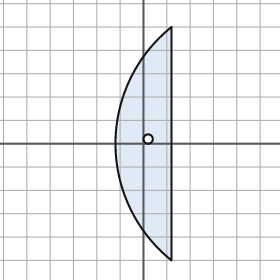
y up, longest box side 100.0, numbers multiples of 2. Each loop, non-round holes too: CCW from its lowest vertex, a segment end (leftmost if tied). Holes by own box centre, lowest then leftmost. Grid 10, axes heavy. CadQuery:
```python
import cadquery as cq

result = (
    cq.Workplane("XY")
    .moveTo(12.0, -50.0)
    .lineTo(12.0, 50.0)
    .threePointArc((-12.0, 0.0), (12.0, -50.0))
    .close()
    .moveTo(2.0, 2.0)
    .circle(2.0)
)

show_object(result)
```